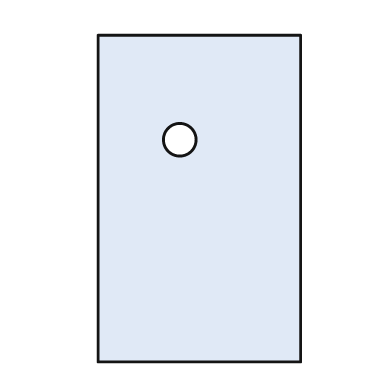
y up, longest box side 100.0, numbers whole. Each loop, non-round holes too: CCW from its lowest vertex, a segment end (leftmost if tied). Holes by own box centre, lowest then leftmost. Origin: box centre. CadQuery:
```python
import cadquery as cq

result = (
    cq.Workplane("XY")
    .moveTo(-31.0, -50.0)
    .lineTo(31.0, -50.0)
    .lineTo(31.0, 50.0)
    .lineTo(-31.0, 50.0)
    .close()
    .moveTo(-6.0, 18.0)
    .circle(5.0)
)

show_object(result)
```